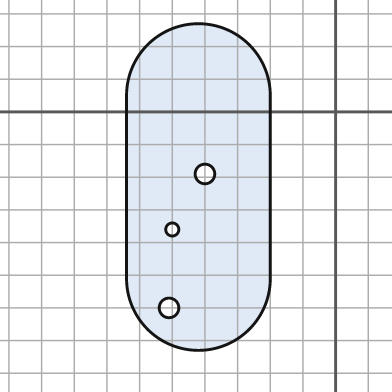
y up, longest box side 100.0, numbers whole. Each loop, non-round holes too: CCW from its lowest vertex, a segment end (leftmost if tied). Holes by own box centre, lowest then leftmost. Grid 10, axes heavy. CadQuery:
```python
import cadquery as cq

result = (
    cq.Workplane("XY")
    .moveTo(-64.0, -51.0)
    .threePointArc((-42.0, -73.0), (-20.0, -51.0))
    .lineTo(-20.0, 5.0)
    .threePointArc((-42.0, 27.0), (-64.0, 5.0))
    .close()
    .moveTo(-51.0, -60.0)
    .circle(3.0)
    .moveTo(-50.0, -36.0)
    .circle(2.0)
    .moveTo(-40.0, -19.0)
    .circle(3.0)
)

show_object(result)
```